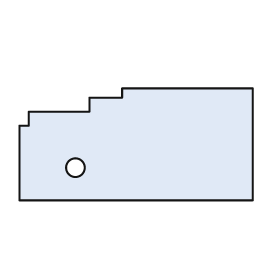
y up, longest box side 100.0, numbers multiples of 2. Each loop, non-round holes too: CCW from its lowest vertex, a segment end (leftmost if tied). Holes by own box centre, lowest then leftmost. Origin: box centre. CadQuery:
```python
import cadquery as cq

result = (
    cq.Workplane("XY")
    .moveTo(-50.0, -24.0)
    .lineTo(50.0, -24.0)
    .lineTo(50.0, 24.0)
    .lineTo(-6.0, 24.0)
    .lineTo(-6.0, 20.0)
    .lineTo(-20.0, 20.0)
    .lineTo(-20.0, 14.0)
    .lineTo(-46.0, 14.0)
    .lineTo(-46.0, 8.0)
    .lineTo(-50.0, 8.0)
    .close()
    .moveTo(-26.0, -10.0)
    .circle(4.0)
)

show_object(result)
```